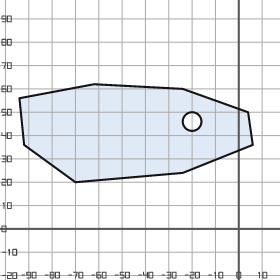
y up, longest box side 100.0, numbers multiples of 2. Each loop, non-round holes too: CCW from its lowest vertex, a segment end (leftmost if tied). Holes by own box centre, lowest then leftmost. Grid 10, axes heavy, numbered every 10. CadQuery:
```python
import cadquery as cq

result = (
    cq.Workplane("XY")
    .moveTo(-70.0, 20.0)
    .lineTo(-24.0, 24.0)
    .lineTo(6.0, 36.0)
    .lineTo(4.0, 50.0)
    .lineTo(-24.0, 60.0)
    .lineTo(-62.0, 62.0)
    .lineTo(-94.0, 56.0)
    .lineTo(-92.0, 36.0)
    .close()
    .moveTo(-20.0, 46.0)
    .circle(4.0)
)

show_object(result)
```